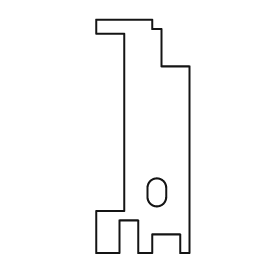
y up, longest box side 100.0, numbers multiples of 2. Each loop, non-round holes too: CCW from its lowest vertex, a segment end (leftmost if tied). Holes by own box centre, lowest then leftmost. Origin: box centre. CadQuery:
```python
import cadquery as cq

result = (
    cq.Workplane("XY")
    .moveTo(-20.0, -50.0)
    .lineTo(-10.0, -50.0)
    .lineTo(-10.0, -36.0)
    .lineTo(-2.0, -36.0)
    .lineTo(-2.0, -50.0)
    .lineTo(4.0, -50.0)
    .lineTo(4.0, -42.0)
    .lineTo(16.0, -42.0)
    .lineTo(16.0, -50.0)
    .lineTo(20.0, -50.0)
    .lineTo(20.0, 30.0)
    .lineTo(8.0, 30.0)
    .lineTo(8.0, 46.0)
    .lineTo(4.0, 46.0)
    .lineTo(4.0, 50.0)
    .lineTo(-20.0, 50.0)
    .lineTo(-20.0, 44.0)
    .lineTo(-8.0, 44.0)
    .lineTo(-8.0, -32.0)
    .lineTo(-20.0, -32.0)
    .close()
    .moveTo(2.0, -26.0)
    .threePointArc((6.0, -30.0), (10.0, -26.0))
    .lineTo(10.0, -22.0)
    .threePointArc((6.0, -18.0), (2.0, -22.0))
    .close()
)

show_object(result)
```